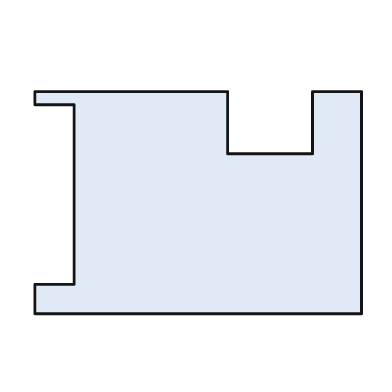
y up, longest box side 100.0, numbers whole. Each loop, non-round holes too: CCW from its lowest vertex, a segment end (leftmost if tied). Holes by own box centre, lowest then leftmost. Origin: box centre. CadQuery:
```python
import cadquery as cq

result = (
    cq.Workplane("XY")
    .moveTo(-50.0, -34.0)
    .lineTo(50.0, -34.0)
    .lineTo(50.0, 34.0)
    .lineTo(35.0, 34.0)
    .lineTo(35.0, 15.0)
    .lineTo(9.0, 15.0)
    .lineTo(9.0, 34.0)
    .lineTo(-50.0, 34.0)
    .lineTo(-50.0, 30.0)
    .lineTo(-38.0, 30.0)
    .lineTo(-38.0, -25.0)
    .lineTo(-50.0, -25.0)
    .close()
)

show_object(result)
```